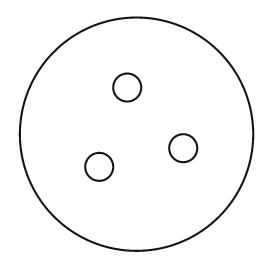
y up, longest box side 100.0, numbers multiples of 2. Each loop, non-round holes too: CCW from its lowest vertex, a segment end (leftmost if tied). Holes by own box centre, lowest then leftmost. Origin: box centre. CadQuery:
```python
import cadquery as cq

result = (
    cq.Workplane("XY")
    .moveTo(0.0, 0.0)
    .circle(50.0)
    .moveTo(-16.0, -14.0)
    .circle(6.0)
    .moveTo(20.0, -6.0)
    .circle(6.0)
    .moveTo(-4.0, 20.0)
    .circle(6.0)
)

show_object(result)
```